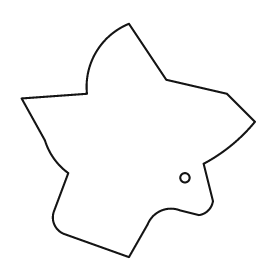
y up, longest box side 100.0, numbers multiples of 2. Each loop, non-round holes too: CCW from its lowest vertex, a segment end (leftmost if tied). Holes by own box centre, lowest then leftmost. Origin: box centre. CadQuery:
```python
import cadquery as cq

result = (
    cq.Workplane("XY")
    .moveTo(-4.0, -50.0)
    .lineTo(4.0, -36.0)
    .threePointArc((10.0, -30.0), (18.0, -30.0))
    .lineTo(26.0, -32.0)
    .threePointArc((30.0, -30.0), (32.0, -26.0))
    .lineTo(28.0, -10.0)
    .threePointArc((40.0, -2.0), (50.0, 8.0))
    .lineTo(38.0, 20.0)
    .lineTo(12.0, 26.0)
    .lineTo(-4.0, 50.0)
    .threePointArc((-18.0, 38.0), (-22.0, 20.0))
    .lineTo(-50.0, 18.0)
    .lineTo(-40.0, 0.0)
    .threePointArc((-36.0, -8.0), (-30.0, -14.0))
    .lineTo(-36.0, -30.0)
    .threePointArc((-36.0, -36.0), (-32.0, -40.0))
    .close()
    .moveTo(20.0, -16.0)
    .circle(2.0)
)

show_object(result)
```